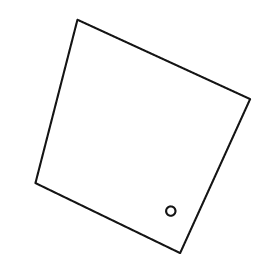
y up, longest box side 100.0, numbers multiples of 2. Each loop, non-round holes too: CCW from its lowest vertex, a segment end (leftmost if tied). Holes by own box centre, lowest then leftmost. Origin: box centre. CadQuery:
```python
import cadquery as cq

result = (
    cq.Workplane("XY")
    .moveTo(16.0, -50.0)
    .lineTo(46.0, 16.0)
    .lineTo(-28.0, 50.0)
    .lineTo(-46.0, -20.0)
    .close()
    .moveTo(12.0, -32.0)
    .circle(2.0)
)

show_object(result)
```